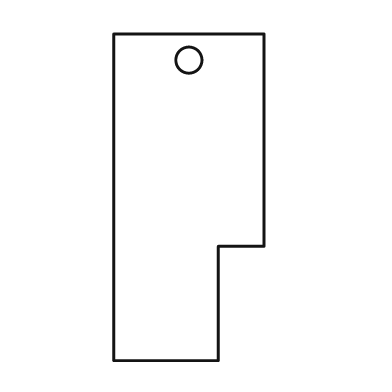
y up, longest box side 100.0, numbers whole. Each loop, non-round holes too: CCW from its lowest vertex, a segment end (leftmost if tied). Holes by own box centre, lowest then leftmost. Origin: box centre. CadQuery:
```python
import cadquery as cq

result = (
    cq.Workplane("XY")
    .moveTo(-23.0, -50.0)
    .lineTo(9.0, -50.0)
    .lineTo(9.0, -15.0)
    .lineTo(23.0, -15.0)
    .lineTo(23.0, 50.0)
    .lineTo(-23.0, 50.0)
    .close()
    .moveTo(0.0, 42.0)
    .circle(4.0)
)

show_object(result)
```